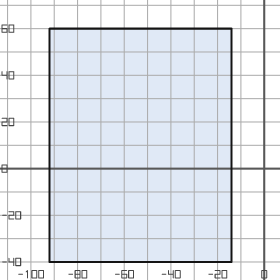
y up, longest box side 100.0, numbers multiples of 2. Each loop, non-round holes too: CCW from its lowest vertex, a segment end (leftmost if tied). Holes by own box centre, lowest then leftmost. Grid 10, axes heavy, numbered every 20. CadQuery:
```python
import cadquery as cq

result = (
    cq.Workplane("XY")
    .moveTo(-92.0, -40.0)
    .lineTo(-14.0, -40.0)
    .lineTo(-14.0, 60.0)
    .lineTo(-92.0, 60.0)
    .close()
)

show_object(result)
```